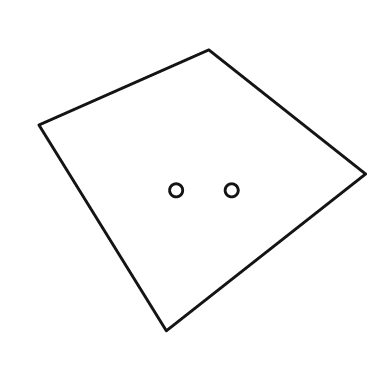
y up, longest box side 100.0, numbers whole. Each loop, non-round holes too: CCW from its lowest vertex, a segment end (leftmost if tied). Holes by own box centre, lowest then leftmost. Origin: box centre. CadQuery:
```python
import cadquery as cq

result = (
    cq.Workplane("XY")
    .moveTo(-11.0, -43.0)
    .lineTo(50.0, 5.0)
    .lineTo(2.0, 43.0)
    .lineTo(-50.0, 20.0)
    .close()
    .moveTo(-8.0, 0.0)
    .circle(2.0)
    .moveTo(9.0, 0.0)
    .circle(2.0)
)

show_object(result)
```